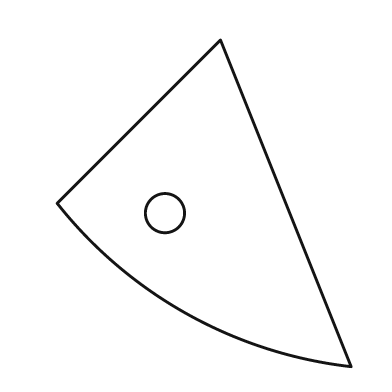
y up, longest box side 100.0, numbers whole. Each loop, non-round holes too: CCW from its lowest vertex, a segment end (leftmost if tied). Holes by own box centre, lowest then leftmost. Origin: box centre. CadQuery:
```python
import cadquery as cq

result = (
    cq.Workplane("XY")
    .moveTo(45.0, -50.0)
    .lineTo(5.0, 50.0)
    .lineTo(-45.0, 0.0)
    .threePointArc((-5.0, -34.0), (45.0, -50.0))
    .close()
    .moveTo(-12.0, -3.0)
    .circle(6.0)
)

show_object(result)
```